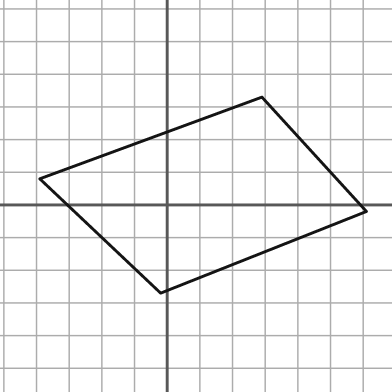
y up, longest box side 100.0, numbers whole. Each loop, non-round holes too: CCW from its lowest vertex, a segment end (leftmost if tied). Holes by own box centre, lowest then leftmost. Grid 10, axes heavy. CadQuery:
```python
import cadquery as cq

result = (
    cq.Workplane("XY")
    .moveTo(-2.0, -27.0)
    .lineTo(61.0, -2.0)
    .lineTo(29.0, 33.0)
    .lineTo(-39.0, 8.0)
    .close()
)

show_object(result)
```